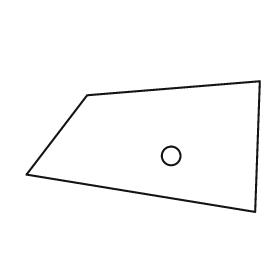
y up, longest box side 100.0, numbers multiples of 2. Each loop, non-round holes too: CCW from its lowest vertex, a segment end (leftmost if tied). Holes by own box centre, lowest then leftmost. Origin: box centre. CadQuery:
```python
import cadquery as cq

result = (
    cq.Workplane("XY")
    .moveTo(48.0, -28.0)
    .lineTo(50.0, 28.0)
    .lineTo(-24.0, 22.0)
    .lineTo(-50.0, -12.0)
    .close()
    .moveTo(12.0, -4.0)
    .circle(4.0)
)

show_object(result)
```